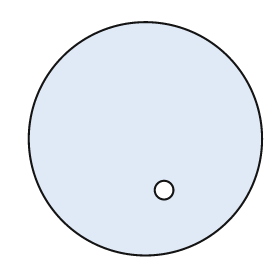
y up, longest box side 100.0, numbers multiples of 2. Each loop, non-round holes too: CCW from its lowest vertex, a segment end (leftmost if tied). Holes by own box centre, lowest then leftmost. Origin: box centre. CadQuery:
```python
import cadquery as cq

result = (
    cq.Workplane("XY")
    .moveTo(0.0, 0.0)
    .circle(50.0)
    .moveTo(8.0, -22.0)
    .circle(4.0)
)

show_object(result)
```